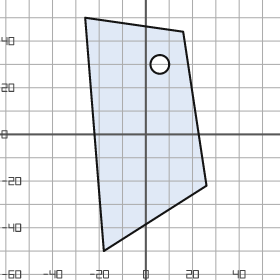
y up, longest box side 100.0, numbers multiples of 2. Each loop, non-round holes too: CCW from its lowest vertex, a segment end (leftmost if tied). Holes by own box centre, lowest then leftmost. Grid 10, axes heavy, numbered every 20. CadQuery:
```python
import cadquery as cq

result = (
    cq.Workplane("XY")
    .moveTo(-18.0, -50.0)
    .lineTo(26.0, -22.0)
    .lineTo(16.0, 44.0)
    .lineTo(-26.0, 50.0)
    .close()
    .moveTo(6.0, 30.0)
    .circle(4.0)
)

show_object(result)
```